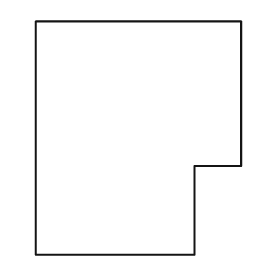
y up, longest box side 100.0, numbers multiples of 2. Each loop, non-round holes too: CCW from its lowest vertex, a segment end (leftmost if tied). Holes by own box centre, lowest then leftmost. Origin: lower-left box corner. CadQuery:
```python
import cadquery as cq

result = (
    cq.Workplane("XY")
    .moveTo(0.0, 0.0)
    .lineTo(68.0, 0.0)
    .lineTo(68.0, 38.0)
    .lineTo(88.0, 38.0)
    .lineTo(88.0, 100.0)
    .lineTo(0.0, 100.0)
    .close()
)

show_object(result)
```